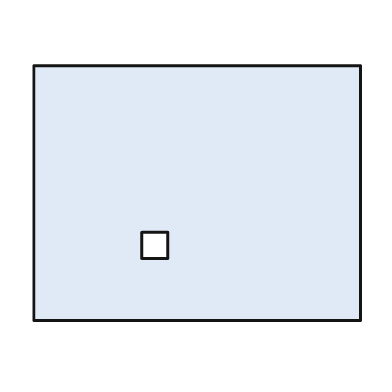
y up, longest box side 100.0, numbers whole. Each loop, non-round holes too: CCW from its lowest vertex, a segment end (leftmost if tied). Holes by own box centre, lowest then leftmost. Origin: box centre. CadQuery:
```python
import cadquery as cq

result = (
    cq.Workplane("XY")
    .moveTo(-50.0, -39.0)
    .lineTo(50.0, -39.0)
    .lineTo(50.0, 39.0)
    .lineTo(-50.0, 39.0)
    .close()
    .moveTo(-17.0, -20.0)
    .lineTo(-9.0, -20.0)
    .lineTo(-9.0, -12.0)
    .lineTo(-17.0, -12.0)
    .close()
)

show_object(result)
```